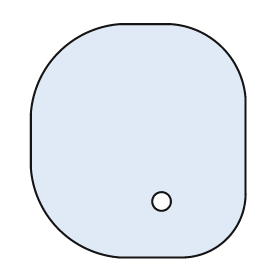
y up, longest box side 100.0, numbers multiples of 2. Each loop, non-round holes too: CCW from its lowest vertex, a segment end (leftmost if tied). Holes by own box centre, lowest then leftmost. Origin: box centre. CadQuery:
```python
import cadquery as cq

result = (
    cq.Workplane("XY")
    .moveTo(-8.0, -50.0)
    .lineTo(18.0, -50.0)
    .threePointArc((38.0, -42.0), (46.0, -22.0))
    .lineTo(46.0, 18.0)
    .threePointArc((36.0, 40.0), (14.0, 50.0))
    .lineTo(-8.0, 50.0)
    .threePointArc((-34.0, 38.0), (-46.0, 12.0))
    .lineTo(-46.0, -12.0)
    .threePointArc((-34.0, -38.0), (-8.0, -50.0))
    .close()
    .moveTo(10.0, -26.0)
    .circle(4.0)
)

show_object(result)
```